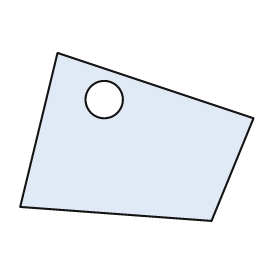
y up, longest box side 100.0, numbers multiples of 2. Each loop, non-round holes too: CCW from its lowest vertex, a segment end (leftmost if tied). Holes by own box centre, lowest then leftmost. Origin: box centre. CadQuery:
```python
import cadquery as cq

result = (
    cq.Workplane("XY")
    .moveTo(32.0, -36.0)
    .lineTo(50.0, 8.0)
    .lineTo(-34.0, 36.0)
    .lineTo(-50.0, -30.0)
    .close()
    .moveTo(-14.0, 16.0)
    .circle(8.0)
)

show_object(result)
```